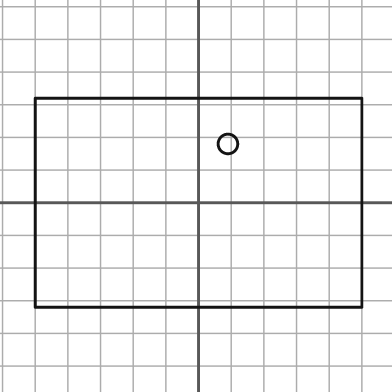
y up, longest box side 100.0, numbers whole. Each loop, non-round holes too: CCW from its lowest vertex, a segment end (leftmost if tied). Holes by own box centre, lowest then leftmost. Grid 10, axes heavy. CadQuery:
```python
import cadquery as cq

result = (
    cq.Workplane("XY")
    .moveTo(-50.0, -32.0)
    .lineTo(50.0, -32.0)
    .lineTo(50.0, 32.0)
    .lineTo(-50.0, 32.0)
    .close()
    .moveTo(9.0, 18.0)
    .circle(3.0)
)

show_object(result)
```